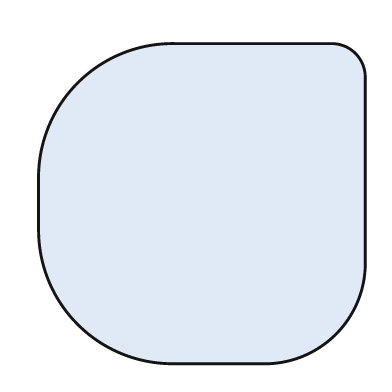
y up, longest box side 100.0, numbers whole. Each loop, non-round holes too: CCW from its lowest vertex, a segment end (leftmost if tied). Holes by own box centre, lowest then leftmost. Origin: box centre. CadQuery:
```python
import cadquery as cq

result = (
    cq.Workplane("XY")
    .moveTo(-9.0, -49.0)
    .lineTo(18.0, -49.0)
    .threePointArc((41.0, -40.0), (50.0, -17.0))
    .lineTo(50.0, 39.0)
    .threePointArc((47.0, 46.0), (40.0, 49.0))
    .lineTo(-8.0, 49.0)
    .threePointArc((-38.0, 37.0), (-50.0, 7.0))
    .lineTo(-50.0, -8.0)
    .threePointArc((-38.0, -37.0), (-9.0, -49.0))
    .close()
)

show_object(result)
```